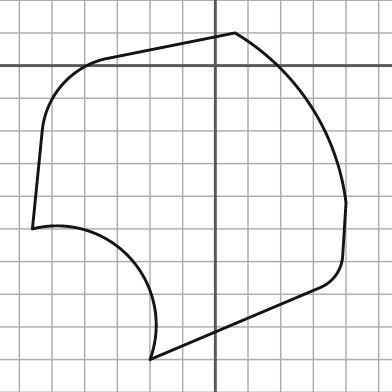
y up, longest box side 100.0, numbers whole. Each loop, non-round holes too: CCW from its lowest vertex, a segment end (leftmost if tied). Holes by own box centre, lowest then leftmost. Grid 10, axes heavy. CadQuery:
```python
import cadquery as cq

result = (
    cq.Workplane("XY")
    .moveTo(-20.0, -90.0)
    .lineTo(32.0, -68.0)
    .threePointArc((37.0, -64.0), (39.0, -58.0))
    .lineTo(40.0, -42.0)
    .threePointArc((29.0, -12.0), (6.0, 10.0))
    .lineTo(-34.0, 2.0)
    .threePointArc((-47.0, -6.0), (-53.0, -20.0))
    .lineTo(-56.0, -50.0)
    .threePointArc((-26.0, -59.0), (-20.0, -90.0))
    .close()
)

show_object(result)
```